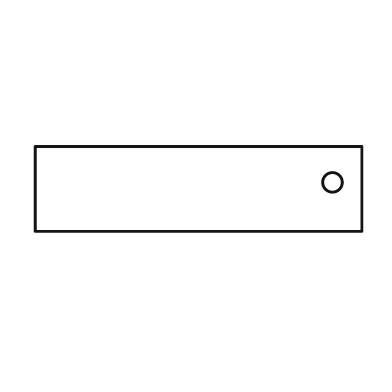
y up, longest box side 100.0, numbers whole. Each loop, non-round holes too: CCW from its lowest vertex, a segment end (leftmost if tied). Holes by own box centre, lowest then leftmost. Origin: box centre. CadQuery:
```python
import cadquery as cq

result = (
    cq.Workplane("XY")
    .moveTo(-50.0, -13.0)
    .lineTo(50.0, -13.0)
    .lineTo(50.0, 13.0)
    .lineTo(-50.0, 13.0)
    .close()
    .moveTo(41.0, 2.0)
    .circle(3.0)
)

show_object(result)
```